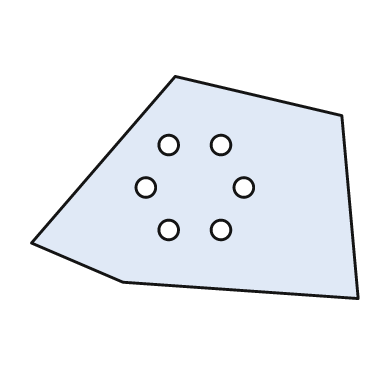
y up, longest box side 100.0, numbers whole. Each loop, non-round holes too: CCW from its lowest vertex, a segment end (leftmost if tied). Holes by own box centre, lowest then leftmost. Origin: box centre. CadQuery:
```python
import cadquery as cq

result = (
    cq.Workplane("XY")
    .moveTo(50.0, -34.0)
    .lineTo(45.0, 22.0)
    .lineTo(-6.0, 34.0)
    .lineTo(-50.0, -17.0)
    .lineTo(-22.0, -29.0)
    .close()
    .moveTo(-8.0, -13.0)
    .circle(3.0)
    .moveTo(8.0, -13.0)
    .circle(3.0)
    .moveTo(-15.0, 0.0)
    .circle(3.0)
    .moveTo(15.0, 0.0)
    .circle(3.0)
    .moveTo(-8.0, 13.0)
    .circle(3.0)
    .moveTo(8.0, 13.0)
    .circle(3.0)
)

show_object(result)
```